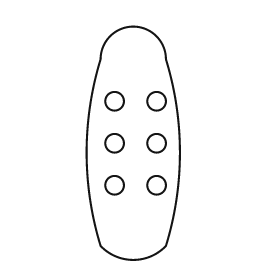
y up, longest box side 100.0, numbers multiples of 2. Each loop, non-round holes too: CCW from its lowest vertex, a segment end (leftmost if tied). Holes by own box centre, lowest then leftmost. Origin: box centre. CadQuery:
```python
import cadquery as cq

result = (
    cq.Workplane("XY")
    .moveTo(-14.0, -44.0)
    .threePointArc((0.0, -50.0), (14.0, -44.0))
    .threePointArc((20.0, -4.0), (14.0, 36.0))
    .threePointArc((0.0, 50.0), (-14.0, 36.0))
    .threePointArc((-20.0, -4.0), (-14.0, -44.0))
    .close()
    .moveTo(-8.0, -18.0)
    .circle(4.0)
    .moveTo(10.0, -18.0)
    .circle(4.0)
    .moveTo(-8.0, 0.0)
    .circle(4.0)
    .moveTo(10.0, 0.0)
    .circle(4.0)
    .moveTo(-8.0, 18.0)
    .circle(4.0)
    .moveTo(10.0, 18.0)
    .circle(4.0)
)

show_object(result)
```